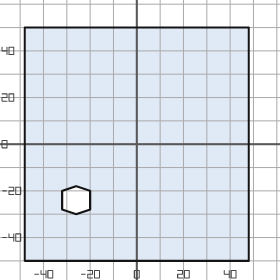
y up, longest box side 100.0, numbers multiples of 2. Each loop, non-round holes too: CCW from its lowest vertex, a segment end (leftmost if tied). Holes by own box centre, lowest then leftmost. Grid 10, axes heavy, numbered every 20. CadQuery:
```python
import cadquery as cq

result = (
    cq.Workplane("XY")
    .moveTo(-48.0, -50.0)
    .lineTo(48.0, -50.0)
    .lineTo(48.0, 50.0)
    .lineTo(-48.0, 50.0)
    .close()
    .moveTo(-26.0, -30.0)
    .lineTo(-20.0, -28.0)
    .lineTo(-20.0, -20.0)
    .lineTo(-26.0, -18.0)
    .lineTo(-32.0, -20.0)
    .lineTo(-32.0, -28.0)
    .close()
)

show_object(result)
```